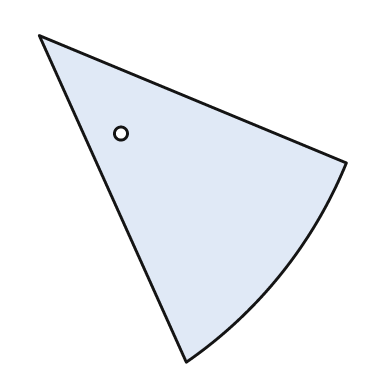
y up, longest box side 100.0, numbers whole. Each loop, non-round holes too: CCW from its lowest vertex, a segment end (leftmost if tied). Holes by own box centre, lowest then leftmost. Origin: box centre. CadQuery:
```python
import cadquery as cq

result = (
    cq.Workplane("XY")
    .moveTo(-2.0, -50.0)
    .threePointArc((27.0, -23.0), (47.0, 11.0))
    .lineTo(-47.0, 50.0)
    .close()
    .moveTo(-22.0, 20.0)
    .circle(2.0)
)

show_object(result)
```